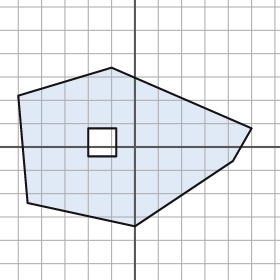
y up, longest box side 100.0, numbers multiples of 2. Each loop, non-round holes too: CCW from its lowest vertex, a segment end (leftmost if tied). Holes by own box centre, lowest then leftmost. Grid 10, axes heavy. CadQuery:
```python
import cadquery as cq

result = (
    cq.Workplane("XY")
    .moveTo(0.0, -34.0)
    .lineTo(42.0, -6.0)
    .lineTo(50.0, 8.0)
    .lineTo(-10.0, 34.0)
    .lineTo(-50.0, 22.0)
    .lineTo(-46.0, -24.0)
    .close()
    .moveTo(-20.0, -4.0)
    .lineTo(-8.0, -4.0)
    .lineTo(-8.0, 8.0)
    .lineTo(-20.0, 8.0)
    .close()
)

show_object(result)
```